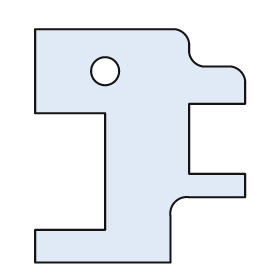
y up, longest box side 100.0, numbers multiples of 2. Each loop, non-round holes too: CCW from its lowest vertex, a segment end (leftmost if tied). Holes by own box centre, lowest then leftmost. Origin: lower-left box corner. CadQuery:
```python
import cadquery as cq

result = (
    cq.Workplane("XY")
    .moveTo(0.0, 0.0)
    .lineTo(58.0, 0.0)
    .lineTo(58.0, 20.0)
    .threePointArc((60.0, 26.0), (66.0, 28.0))
    .lineTo(90.0, 28.0)
    .lineTo(90.0, 38.0)
    .lineTo(66.0, 38.0)
    .lineTo(66.0, 68.0)
    .lineTo(90.0, 68.0)
    .lineTo(90.0, 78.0)
    .threePointArc((88.0, 82.0), (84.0, 84.0))
    .lineTo(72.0, 84.0)
    .threePointArc((68.0, 86.0), (66.0, 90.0))
    .lineTo(66.0, 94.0)
    .threePointArc((64.0, 98.0), (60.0, 100.0))
    .lineTo(0.0, 100.0)
    .lineTo(0.0, 64.0)
    .lineTo(30.0, 64.0)
    .lineTo(30.0, 14.0)
    .lineTo(0.0, 14.0)
    .close()
    .moveTo(30.0, 82.0)
    .circle(6.0)
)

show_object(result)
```